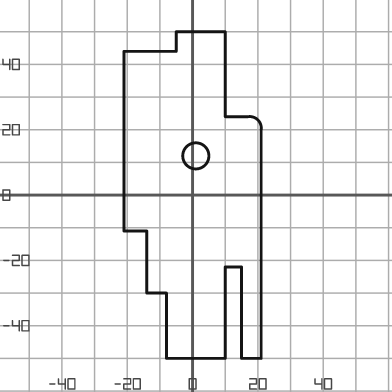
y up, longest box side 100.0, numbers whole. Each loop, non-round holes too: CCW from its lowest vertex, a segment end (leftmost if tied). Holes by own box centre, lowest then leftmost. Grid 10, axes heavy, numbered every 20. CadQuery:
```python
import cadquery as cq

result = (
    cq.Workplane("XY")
    .moveTo(-8.0, -50.0)
    .lineTo(10.0, -50.0)
    .lineTo(10.0, -22.0)
    .lineTo(15.0, -22.0)
    .lineTo(15.0, -50.0)
    .lineTo(21.0, -50.0)
    .lineTo(21.0, 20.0)
    .threePointArc((20.0, 23.0), (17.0, 24.0))
    .lineTo(10.0, 24.0)
    .lineTo(10.0, 50.0)
    .lineTo(-5.0, 50.0)
    .lineTo(-5.0, 44.0)
    .lineTo(-21.0, 44.0)
    .lineTo(-21.0, -11.0)
    .lineTo(-14.0, -11.0)
    .lineTo(-14.0, -30.0)
    .lineTo(-8.0, -30.0)
    .close()
    .moveTo(1.0, 12.0)
    .circle(4.0)
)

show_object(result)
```